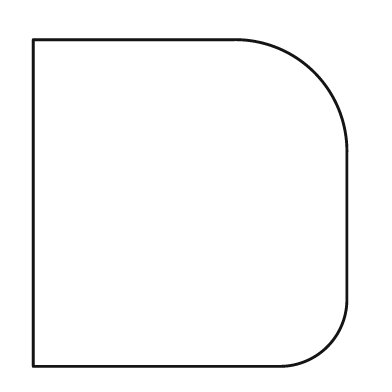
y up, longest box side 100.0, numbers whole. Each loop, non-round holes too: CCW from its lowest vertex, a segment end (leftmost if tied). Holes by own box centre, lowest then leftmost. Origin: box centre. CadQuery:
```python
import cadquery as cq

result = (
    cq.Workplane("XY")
    .moveTo(-48.0, -50.0)
    .lineTo(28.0, -50.0)
    .threePointArc((42.0, -44.0), (48.0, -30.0))
    .lineTo(48.0, 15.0)
    .threePointArc((38.0, 40.0), (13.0, 50.0))
    .lineTo(-48.0, 50.0)
    .close()
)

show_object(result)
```